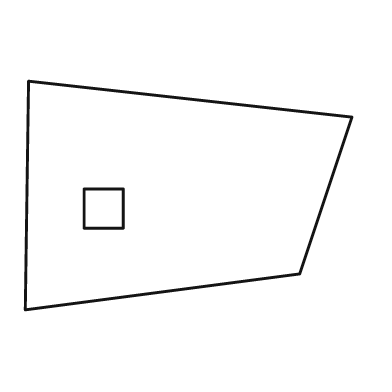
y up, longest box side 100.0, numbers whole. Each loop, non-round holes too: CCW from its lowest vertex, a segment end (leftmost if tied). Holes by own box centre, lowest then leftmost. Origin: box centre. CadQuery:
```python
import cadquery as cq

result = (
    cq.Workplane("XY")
    .moveTo(-50.0, -35.0)
    .lineTo(34.0, -24.0)
    .lineTo(50.0, 24.0)
    .lineTo(-49.0, 35.0)
    .close()
    .moveTo(-32.0, -10.0)
    .lineTo(-20.0, -10.0)
    .lineTo(-20.0, 2.0)
    .lineTo(-32.0, 2.0)
    .close()
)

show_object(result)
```